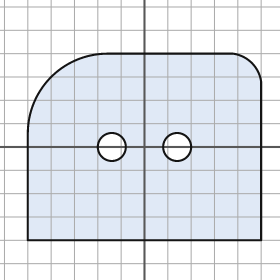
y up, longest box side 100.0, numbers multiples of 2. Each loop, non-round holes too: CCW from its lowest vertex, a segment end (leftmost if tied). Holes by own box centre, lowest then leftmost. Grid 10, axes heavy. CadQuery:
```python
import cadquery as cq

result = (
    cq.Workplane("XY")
    .moveTo(-50.0, -40.0)
    .lineTo(50.0, -40.0)
    .lineTo(50.0, 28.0)
    .threePointArc((46.0, 36.0), (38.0, 40.0))
    .lineTo(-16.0, 40.0)
    .threePointArc((-40.0, 30.0), (-50.0, 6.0))
    .close()
    .moveTo(-14.0, 0.0)
    .circle(6.0)
    .moveTo(14.0, 0.0)
    .circle(6.0)
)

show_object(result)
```